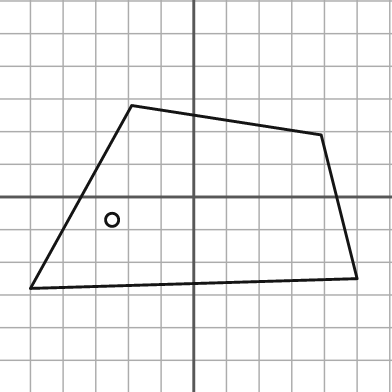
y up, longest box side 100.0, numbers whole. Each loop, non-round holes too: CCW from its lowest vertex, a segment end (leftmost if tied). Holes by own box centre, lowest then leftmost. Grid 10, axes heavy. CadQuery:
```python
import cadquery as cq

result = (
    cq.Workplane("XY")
    .moveTo(-50.0, -28.0)
    .lineTo(50.0, -25.0)
    .lineTo(39.0, 19.0)
    .lineTo(-19.0, 28.0)
    .close()
    .moveTo(-25.0, -7.0)
    .circle(2.0)
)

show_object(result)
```